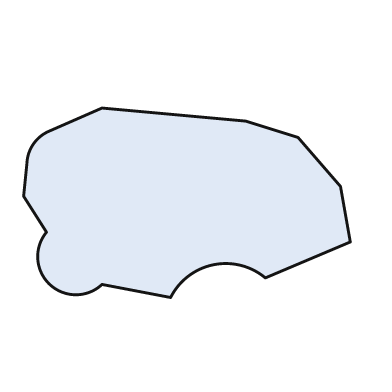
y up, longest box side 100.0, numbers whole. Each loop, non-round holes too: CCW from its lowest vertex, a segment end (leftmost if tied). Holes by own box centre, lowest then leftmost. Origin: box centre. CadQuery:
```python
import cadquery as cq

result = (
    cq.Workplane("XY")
    .moveTo(-5.0, -29.0)
    .threePointArc((8.0, -19.0), (24.0, -23.0))
    .lineTo(50.0, -12.0)
    .lineTo(47.0, 5.0)
    .lineTo(34.0, 20.0)
    .lineTo(18.0, 25.0)
    .lineTo(-26.0, 29.0)
    .lineTo(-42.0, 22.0)
    .threePointArc((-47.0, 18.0), (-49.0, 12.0))
    .lineTo(-50.0, 2.0)
    .lineTo(-43.0, -9.0)
    .threePointArc((-42.0, -25.0), (-26.0, -25.0))
    .close()
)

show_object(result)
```